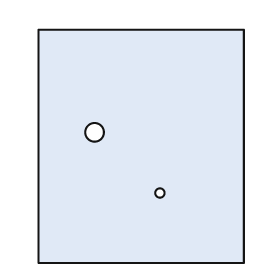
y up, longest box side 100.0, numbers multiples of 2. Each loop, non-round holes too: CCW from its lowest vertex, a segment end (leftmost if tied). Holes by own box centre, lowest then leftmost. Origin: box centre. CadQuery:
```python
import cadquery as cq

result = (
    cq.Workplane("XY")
    .moveTo(-44.0, -50.0)
    .lineTo(44.0, -50.0)
    .lineTo(44.0, 50.0)
    .lineTo(-44.0, 50.0)
    .close()
    .moveTo(8.0, -20.0)
    .circle(2.0)
    .moveTo(-20.0, 6.0)
    .circle(4.0)
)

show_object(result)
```